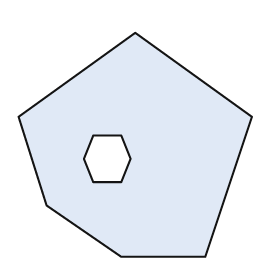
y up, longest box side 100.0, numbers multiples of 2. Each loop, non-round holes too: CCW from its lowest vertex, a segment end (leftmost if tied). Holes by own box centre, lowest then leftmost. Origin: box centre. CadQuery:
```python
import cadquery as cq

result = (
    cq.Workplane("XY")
    .moveTo(-6.0, -48.0)
    .lineTo(30.0, -48.0)
    .lineTo(50.0, 12.0)
    .lineTo(0.0, 48.0)
    .lineTo(-50.0, 12.0)
    .lineTo(-38.0, -26.0)
    .close()
    .moveTo(-18.0, -16.0)
    .lineTo(-6.0, -16.0)
    .lineTo(-2.0, -6.0)
    .lineTo(-6.0, 4.0)
    .lineTo(-18.0, 4.0)
    .lineTo(-22.0, -6.0)
    .close()
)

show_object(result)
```